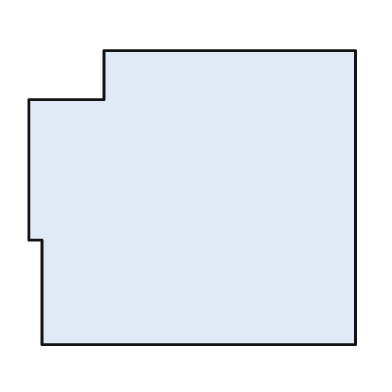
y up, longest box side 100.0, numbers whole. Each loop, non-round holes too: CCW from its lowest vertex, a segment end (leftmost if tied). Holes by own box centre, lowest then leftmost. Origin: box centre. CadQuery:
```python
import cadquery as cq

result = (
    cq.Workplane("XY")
    .moveTo(-46.0, -45.0)
    .lineTo(50.0, -45.0)
    .lineTo(50.0, 45.0)
    .lineTo(-27.0, 45.0)
    .lineTo(-27.0, 30.0)
    .lineTo(-50.0, 30.0)
    .lineTo(-50.0, -13.0)
    .lineTo(-46.0, -13.0)
    .close()
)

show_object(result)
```